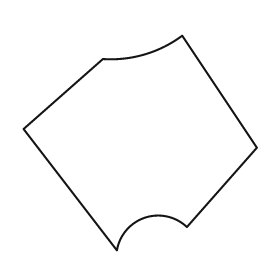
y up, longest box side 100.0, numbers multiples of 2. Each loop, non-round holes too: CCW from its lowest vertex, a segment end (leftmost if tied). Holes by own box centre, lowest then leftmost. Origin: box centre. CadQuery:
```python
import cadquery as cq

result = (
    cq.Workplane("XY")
    .moveTo(-10.0, -46.0)
    .threePointArc((2.0, -32.0), (20.0, -36.0))
    .lineTo(50.0, -2.0)
    .lineTo(18.0, 46.0)
    .threePointArc((2.0, 38.0), (-16.0, 36.0))
    .lineTo(-50.0, 6.0)
    .close()
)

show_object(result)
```